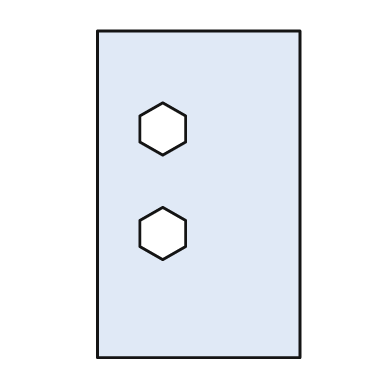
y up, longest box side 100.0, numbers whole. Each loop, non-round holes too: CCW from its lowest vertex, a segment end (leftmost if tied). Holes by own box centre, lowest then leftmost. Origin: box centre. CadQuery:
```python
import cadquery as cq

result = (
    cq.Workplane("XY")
    .moveTo(-31.0, -50.0)
    .lineTo(31.0, -50.0)
    .lineTo(31.0, 50.0)
    .lineTo(-31.0, 50.0)
    .close()
    .moveTo(-11.0, -20.0)
    .lineTo(-4.0, -16.0)
    .lineTo(-4.0, -8.0)
    .lineTo(-11.0, -4.0)
    .lineTo(-18.0, -8.0)
    .lineTo(-18.0, -16.0)
    .close()
    .moveTo(-11.0, 12.0)
    .lineTo(-4.0, 16.0)
    .lineTo(-4.0, 24.0)
    .lineTo(-11.0, 28.0)
    .lineTo(-18.0, 24.0)
    .lineTo(-18.0, 16.0)
    .close()
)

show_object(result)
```